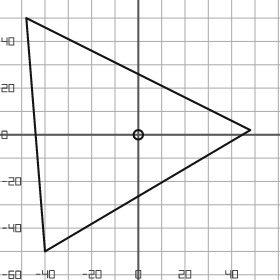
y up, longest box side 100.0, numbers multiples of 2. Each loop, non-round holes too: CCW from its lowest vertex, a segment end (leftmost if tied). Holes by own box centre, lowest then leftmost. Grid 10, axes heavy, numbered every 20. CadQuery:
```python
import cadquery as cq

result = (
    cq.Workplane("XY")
    .moveTo(-40.0, -50.0)
    .lineTo(48.0, 2.0)
    .lineTo(-48.0, 50.0)
    .close()
    .moveTo(0.0, 0.0)
    .circle(2.0)
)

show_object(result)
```